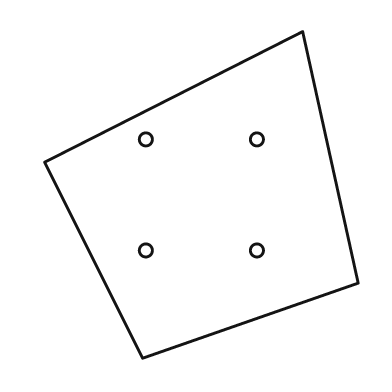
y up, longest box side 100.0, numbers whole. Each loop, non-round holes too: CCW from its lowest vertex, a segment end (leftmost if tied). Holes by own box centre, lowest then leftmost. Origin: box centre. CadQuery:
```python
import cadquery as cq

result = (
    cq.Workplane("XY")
    .moveTo(-18.0, -50.0)
    .lineTo(48.0, -27.0)
    .lineTo(31.0, 50.0)
    .lineTo(-48.0, 10.0)
    .close()
    .moveTo(-17.0, -17.0)
    .circle(2.0)
    .moveTo(17.0, -17.0)
    .circle(2.0)
    .moveTo(-17.0, 17.0)
    .circle(2.0)
    .moveTo(17.0, 17.0)
    .circle(2.0)
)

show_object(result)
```